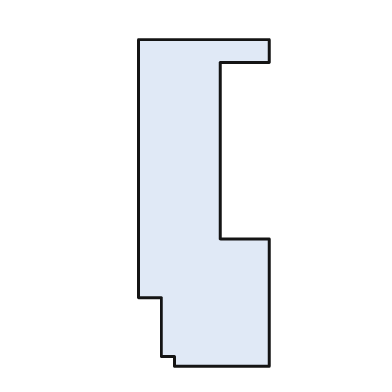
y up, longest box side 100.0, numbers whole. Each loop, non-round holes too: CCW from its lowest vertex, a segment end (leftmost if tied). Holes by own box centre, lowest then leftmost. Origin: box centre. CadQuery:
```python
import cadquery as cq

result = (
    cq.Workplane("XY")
    .moveTo(-9.0, -50.0)
    .lineTo(20.0, -50.0)
    .lineTo(20.0, -11.0)
    .lineTo(5.0, -11.0)
    .lineTo(5.0, 43.0)
    .lineTo(20.0, 43.0)
    .lineTo(20.0, 50.0)
    .lineTo(-20.0, 50.0)
    .lineTo(-20.0, -29.0)
    .lineTo(-13.0, -29.0)
    .lineTo(-13.0, -47.0)
    .lineTo(-9.0, -47.0)
    .close()
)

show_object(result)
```